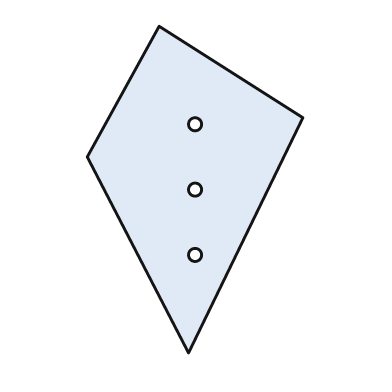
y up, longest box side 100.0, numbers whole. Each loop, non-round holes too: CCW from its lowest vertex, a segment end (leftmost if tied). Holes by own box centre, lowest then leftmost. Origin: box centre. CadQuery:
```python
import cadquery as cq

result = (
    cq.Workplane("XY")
    .moveTo(-2.0, -50.0)
    .lineTo(33.0, 22.0)
    .lineTo(-11.0, 50.0)
    .lineTo(-33.0, 10.0)
    .close()
    .moveTo(0.0, -20.0)
    .circle(2.0)
    .moveTo(0.0, 0.0)
    .circle(2.0)
    .moveTo(0.0, 20.0)
    .circle(2.0)
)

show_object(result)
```